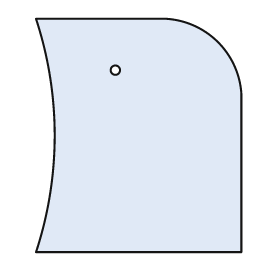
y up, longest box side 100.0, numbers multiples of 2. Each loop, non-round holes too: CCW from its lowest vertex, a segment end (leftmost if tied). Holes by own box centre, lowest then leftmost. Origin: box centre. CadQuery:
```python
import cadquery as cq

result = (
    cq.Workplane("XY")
    .moveTo(-44.0, -50.0)
    .lineTo(44.0, -50.0)
    .lineTo(44.0, 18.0)
    .threePointArc((34.0, 40.0), (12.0, 50.0))
    .lineTo(-44.0, 50.0)
    .threePointArc((-36.0, 0.0), (-44.0, -50.0))
    .close()
    .moveTo(-10.0, 28.0)
    .circle(2.0)
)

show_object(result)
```